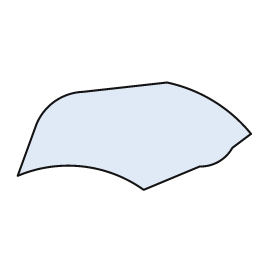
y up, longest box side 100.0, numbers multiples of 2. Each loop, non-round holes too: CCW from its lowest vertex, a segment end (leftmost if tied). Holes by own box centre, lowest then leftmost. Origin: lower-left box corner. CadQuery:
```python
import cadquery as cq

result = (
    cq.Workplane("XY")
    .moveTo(54.0, 0.0)
    .lineTo(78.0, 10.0)
    .threePointArc((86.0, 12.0), (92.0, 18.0))
    .lineTo(100.0, 24.0)
    .threePointArc((84.0, 38.0), (64.0, 46.0))
    .lineTo(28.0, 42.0)
    .threePointArc((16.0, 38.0), (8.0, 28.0))
    .lineTo(0.0, 6.0)
    .threePointArc((28.0, 10.0), (54.0, 0.0))
    .close()
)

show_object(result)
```